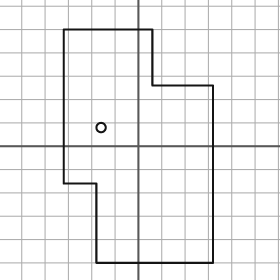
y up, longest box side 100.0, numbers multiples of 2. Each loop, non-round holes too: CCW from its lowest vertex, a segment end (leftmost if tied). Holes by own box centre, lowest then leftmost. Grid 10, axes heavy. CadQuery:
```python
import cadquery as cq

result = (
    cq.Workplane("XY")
    .moveTo(-18.0, -50.0)
    .lineTo(32.0, -50.0)
    .lineTo(32.0, 26.0)
    .lineTo(6.0, 26.0)
    .lineTo(6.0, 50.0)
    .lineTo(-32.0, 50.0)
    .lineTo(-32.0, -16.0)
    .lineTo(-18.0, -16.0)
    .close()
    .moveTo(-16.0, 8.0)
    .circle(2.0)
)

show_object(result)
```